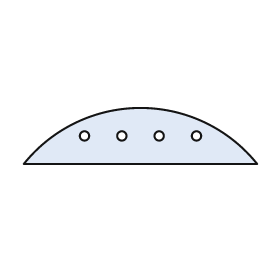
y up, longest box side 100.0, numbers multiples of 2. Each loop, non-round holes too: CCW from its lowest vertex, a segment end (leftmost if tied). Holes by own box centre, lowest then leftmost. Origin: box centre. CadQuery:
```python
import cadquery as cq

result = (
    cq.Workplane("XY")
    .moveTo(-50.0, -12.0)
    .lineTo(50.0, -12.0)
    .threePointArc((0.0, 12.0), (-50.0, -12.0))
    .close()
    .moveTo(-24.0, 0.0)
    .circle(2.0)
    .moveTo(-8.0, 0.0)
    .circle(2.0)
    .moveTo(8.0, 0.0)
    .circle(2.0)
    .moveTo(24.0, 0.0)
    .circle(2.0)
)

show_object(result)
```